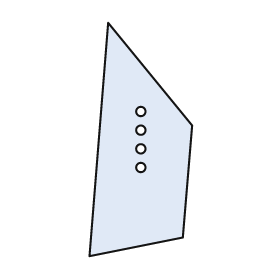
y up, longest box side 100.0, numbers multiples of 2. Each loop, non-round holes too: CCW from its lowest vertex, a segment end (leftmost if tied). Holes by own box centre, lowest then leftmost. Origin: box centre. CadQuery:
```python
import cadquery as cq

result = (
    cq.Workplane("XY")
    .moveTo(-22.0, -50.0)
    .lineTo(18.0, -42.0)
    .lineTo(22.0, 6.0)
    .lineTo(-14.0, 50.0)
    .close()
    .moveTo(0.0, -12.0)
    .circle(2.0)
    .moveTo(0.0, -4.0)
    .circle(2.0)
    .moveTo(0.0, 4.0)
    .circle(2.0)
    .moveTo(0.0, 12.0)
    .circle(2.0)
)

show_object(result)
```